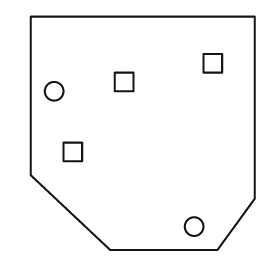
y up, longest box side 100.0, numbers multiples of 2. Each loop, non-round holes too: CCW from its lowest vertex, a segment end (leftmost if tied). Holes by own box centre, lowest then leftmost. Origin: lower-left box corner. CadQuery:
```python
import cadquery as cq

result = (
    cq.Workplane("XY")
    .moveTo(34.0, 0.0)
    .lineTo(80.0, 0.0)
    .lineTo(96.0, 22.0)
    .lineTo(96.0, 100.0)
    .lineTo(0.0, 100.0)
    .lineTo(0.0, 32.0)
    .close()
    .moveTo(70.0, 10.0)
    .circle(4.0)
    .moveTo(14.0, 38.0)
    .lineTo(22.0, 38.0)
    .lineTo(22.0, 46.0)
    .lineTo(14.0, 46.0)
    .close()
    .moveTo(10.0, 68.0)
    .circle(4.0)
    .moveTo(36.0, 68.0)
    .lineTo(44.0, 68.0)
    .lineTo(44.0, 76.0)
    .lineTo(36.0, 76.0)
    .close()
    .moveTo(74.0, 76.0)
    .lineTo(82.0, 76.0)
    .lineTo(82.0, 84.0)
    .lineTo(74.0, 84.0)
    .close()
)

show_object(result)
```